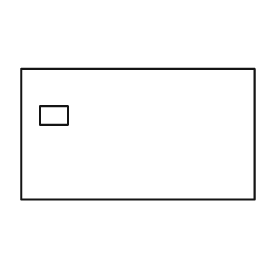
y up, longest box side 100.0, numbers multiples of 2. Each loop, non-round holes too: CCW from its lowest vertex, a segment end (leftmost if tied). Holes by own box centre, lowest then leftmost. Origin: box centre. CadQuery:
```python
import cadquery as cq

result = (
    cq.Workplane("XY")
    .moveTo(-50.0, -28.0)
    .lineTo(50.0, -28.0)
    .lineTo(50.0, 28.0)
    .lineTo(-50.0, 28.0)
    .close()
    .moveTo(-42.0, 4.0)
    .lineTo(-30.0, 4.0)
    .lineTo(-30.0, 12.0)
    .lineTo(-42.0, 12.0)
    .close()
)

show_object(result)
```